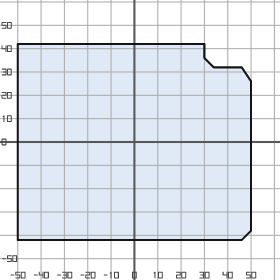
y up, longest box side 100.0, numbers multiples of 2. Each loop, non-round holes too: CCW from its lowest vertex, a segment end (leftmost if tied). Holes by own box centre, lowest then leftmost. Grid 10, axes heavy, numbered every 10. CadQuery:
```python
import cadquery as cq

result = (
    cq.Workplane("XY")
    .moveTo(-50.0, -42.0)
    .lineTo(46.0, -42.0)
    .lineTo(50.0, -38.0)
    .lineTo(50.0, 26.0)
    .lineTo(46.0, 32.0)
    .lineTo(34.0, 32.0)
    .lineTo(30.0, 36.0)
    .lineTo(30.0, 42.0)
    .lineTo(-50.0, 42.0)
    .close()
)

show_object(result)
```